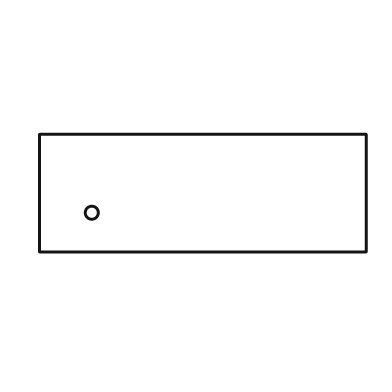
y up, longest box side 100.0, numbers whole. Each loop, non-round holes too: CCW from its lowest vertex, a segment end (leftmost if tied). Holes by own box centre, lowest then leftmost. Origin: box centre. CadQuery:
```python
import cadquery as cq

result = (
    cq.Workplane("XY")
    .moveTo(-50.0, -18.0)
    .lineTo(50.0, -18.0)
    .lineTo(50.0, 18.0)
    .lineTo(-50.0, 18.0)
    .close()
    .moveTo(-34.0, -6.0)
    .circle(2.0)
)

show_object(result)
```